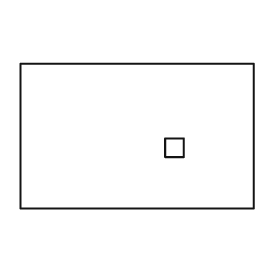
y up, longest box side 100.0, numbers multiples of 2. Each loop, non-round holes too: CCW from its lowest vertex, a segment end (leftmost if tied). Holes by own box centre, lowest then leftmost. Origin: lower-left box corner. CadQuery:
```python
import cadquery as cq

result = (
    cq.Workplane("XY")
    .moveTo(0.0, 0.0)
    .lineTo(100.0, 0.0)
    .lineTo(100.0, 62.0)
    .lineTo(0.0, 62.0)
    .close()
    .moveTo(62.0, 22.0)
    .lineTo(70.0, 22.0)
    .lineTo(70.0, 30.0)
    .lineTo(62.0, 30.0)
    .close()
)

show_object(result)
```